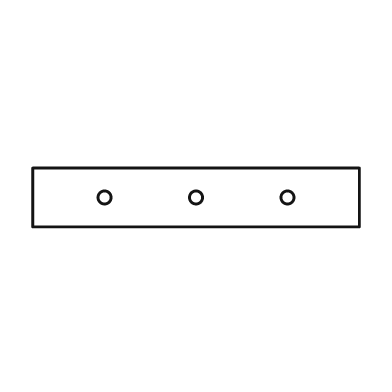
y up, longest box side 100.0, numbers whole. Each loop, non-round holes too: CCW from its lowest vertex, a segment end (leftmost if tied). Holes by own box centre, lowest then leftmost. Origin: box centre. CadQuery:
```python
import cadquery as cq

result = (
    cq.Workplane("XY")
    .moveTo(-50.0, -9.0)
    .lineTo(50.0, -9.0)
    .lineTo(50.0, 9.0)
    .lineTo(-50.0, 9.0)
    .close()
    .moveTo(-28.0, 0.0)
    .circle(2.0)
    .moveTo(0.0, 0.0)
    .circle(2.0)
    .moveTo(28.0, 0.0)
    .circle(2.0)
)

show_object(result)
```